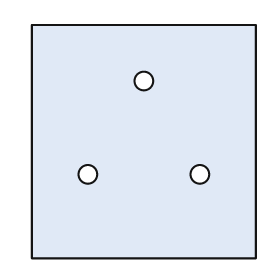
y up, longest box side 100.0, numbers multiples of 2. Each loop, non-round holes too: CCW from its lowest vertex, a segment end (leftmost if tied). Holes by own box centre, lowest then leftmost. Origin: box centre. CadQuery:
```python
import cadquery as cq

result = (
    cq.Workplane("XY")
    .moveTo(-48.0, -50.0)
    .lineTo(48.0, -50.0)
    .lineTo(48.0, 50.0)
    .lineTo(-48.0, 50.0)
    .close()
    .moveTo(-24.0, -14.0)
    .circle(4.0)
    .moveTo(24.0, -14.0)
    .circle(4.0)
    .moveTo(0.0, 26.0)
    .circle(4.0)
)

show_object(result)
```